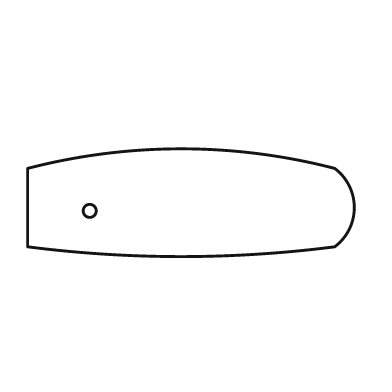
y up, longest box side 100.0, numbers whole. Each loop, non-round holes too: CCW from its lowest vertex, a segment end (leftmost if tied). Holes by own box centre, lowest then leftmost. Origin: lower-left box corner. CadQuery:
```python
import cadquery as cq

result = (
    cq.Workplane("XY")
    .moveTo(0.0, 3.0)
    .threePointArc((47.0, 0.0), (94.0, 3.0))
    .threePointArc((100.0, 15.0), (94.0, 27.0))
    .threePointArc((47.0, 33.0), (0.0, 27.0))
    .close()
    .moveTo(19.0, 14.0)
    .circle(2.0)
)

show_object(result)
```